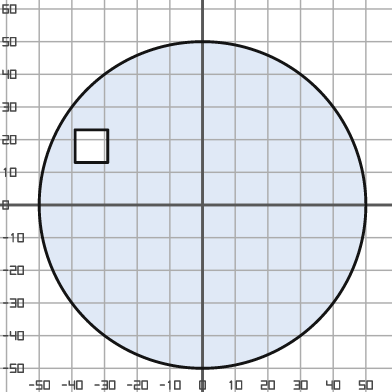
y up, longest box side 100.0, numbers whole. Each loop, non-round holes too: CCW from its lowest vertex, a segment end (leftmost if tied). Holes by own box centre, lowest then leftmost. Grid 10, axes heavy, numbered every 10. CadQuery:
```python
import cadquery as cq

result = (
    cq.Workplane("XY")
    .moveTo(0.0, 0.0)
    .circle(50.0)
    .moveTo(-39.0, 13.0)
    .lineTo(-29.0, 13.0)
    .lineTo(-29.0, 23.0)
    .lineTo(-39.0, 23.0)
    .close()
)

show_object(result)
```